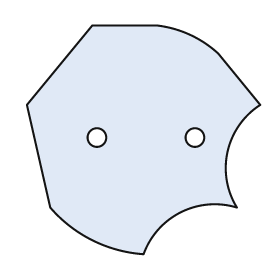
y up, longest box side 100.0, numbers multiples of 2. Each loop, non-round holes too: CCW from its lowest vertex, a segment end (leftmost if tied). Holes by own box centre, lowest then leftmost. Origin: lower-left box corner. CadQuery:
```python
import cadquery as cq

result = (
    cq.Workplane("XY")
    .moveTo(50.0, 0.0)
    .threePointArc((66.0, 18.0), (90.0, 20.0))
    .threePointArc((86.0, 44.0), (100.0, 64.0))
    .lineTo(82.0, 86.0)
    .threePointArc((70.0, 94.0), (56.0, 98.0))
    .lineTo(28.0, 98.0)
    .lineTo(0.0, 64.0)
    .lineTo(10.0, 20.0)
    .threePointArc((28.0, 6.0), (50.0, 0.0))
    .close()
    .moveTo(30.0, 50.0)
    .circle(4.0)
    .moveTo(72.0, 50.0)
    .circle(4.0)
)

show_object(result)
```